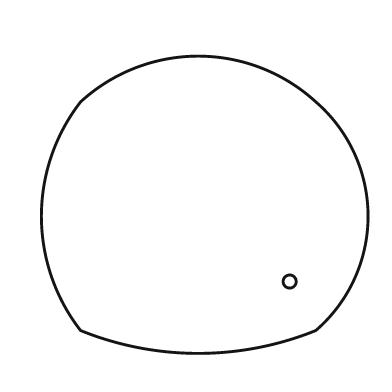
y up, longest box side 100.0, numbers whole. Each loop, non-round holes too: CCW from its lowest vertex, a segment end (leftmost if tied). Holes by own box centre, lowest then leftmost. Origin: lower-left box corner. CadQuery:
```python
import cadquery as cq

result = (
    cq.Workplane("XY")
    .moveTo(12.0, 7.0)
    .threePointArc((48.0, 0.0), (84.0, 7.0))
    .threePointArc((100.0, 42.0), (84.0, 77.0))
    .threePointArc((48.0, 91.0), (12.0, 77.0))
    .threePointArc((0.0, 42.0), (12.0, 7.0))
    .close()
    .moveTo(76.0, 22.0)
    .circle(2.0)
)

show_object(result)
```